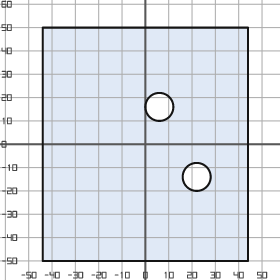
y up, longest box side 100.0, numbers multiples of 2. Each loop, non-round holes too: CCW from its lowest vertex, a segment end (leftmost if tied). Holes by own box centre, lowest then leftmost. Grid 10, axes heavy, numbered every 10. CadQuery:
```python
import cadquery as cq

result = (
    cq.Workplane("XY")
    .moveTo(-44.0, -50.0)
    .lineTo(44.0, -50.0)
    .lineTo(44.0, 50.0)
    .lineTo(-44.0, 50.0)
    .close()
    .moveTo(22.0, -14.0)
    .circle(6.0)
    .moveTo(6.0, 16.0)
    .circle(6.0)
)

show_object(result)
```